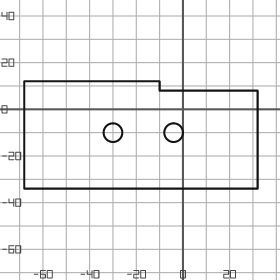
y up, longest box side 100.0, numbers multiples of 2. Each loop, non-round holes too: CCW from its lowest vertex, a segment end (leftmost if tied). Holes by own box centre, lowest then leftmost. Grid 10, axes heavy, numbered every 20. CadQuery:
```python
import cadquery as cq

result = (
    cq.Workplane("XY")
    .moveTo(-68.0, -34.0)
    .lineTo(32.0, -34.0)
    .lineTo(32.0, 8.0)
    .lineTo(-10.0, 8.0)
    .lineTo(-10.0, 12.0)
    .lineTo(-68.0, 12.0)
    .close()
    .moveTo(-30.0, -10.0)
    .circle(4.0)
    .moveTo(-4.0, -10.0)
    .circle(4.0)
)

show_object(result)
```